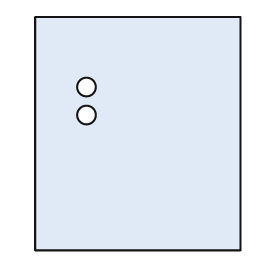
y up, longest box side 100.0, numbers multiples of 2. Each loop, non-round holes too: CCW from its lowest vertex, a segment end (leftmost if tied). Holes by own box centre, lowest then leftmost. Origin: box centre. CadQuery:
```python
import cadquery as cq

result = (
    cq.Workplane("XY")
    .moveTo(-44.0, -50.0)
    .lineTo(44.0, -50.0)
    .lineTo(44.0, 50.0)
    .lineTo(-44.0, 50.0)
    .close()
    .moveTo(-22.0, 8.0)
    .circle(4.0)
    .moveTo(-22.0, 20.0)
    .circle(4.0)
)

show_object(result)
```